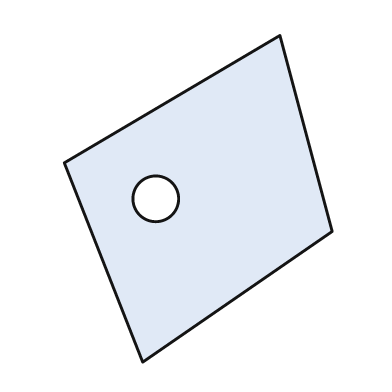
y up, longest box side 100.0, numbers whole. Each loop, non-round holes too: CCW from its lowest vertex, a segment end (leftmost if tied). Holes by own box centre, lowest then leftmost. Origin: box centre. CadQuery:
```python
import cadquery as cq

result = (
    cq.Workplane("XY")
    .moveTo(-17.0, -50.0)
    .lineTo(41.0, -10.0)
    .lineTo(25.0, 50.0)
    .lineTo(-41.0, 11.0)
    .close()
    .moveTo(-13.0, 0.0)
    .circle(7.0)
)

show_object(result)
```